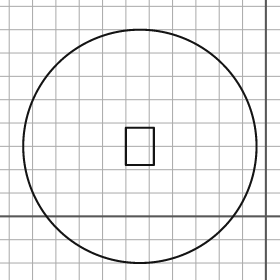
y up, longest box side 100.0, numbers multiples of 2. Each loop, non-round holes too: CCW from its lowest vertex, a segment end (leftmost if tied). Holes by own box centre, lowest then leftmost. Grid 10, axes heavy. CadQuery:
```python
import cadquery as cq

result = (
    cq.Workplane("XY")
    .moveTo(-54.0, 30.0)
    .circle(50.0)
    .moveTo(-60.0, 22.0)
    .lineTo(-48.0, 22.0)
    .lineTo(-48.0, 38.0)
    .lineTo(-60.0, 38.0)
    .close()
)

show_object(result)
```